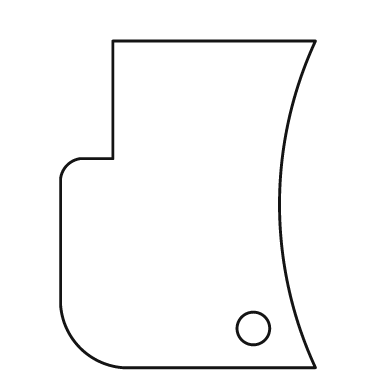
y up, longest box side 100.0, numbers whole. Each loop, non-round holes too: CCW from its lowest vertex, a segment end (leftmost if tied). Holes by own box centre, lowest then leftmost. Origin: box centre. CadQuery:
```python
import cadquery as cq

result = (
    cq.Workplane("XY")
    .moveTo(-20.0, -50.0)
    .lineTo(39.0, -50.0)
    .threePointArc((28.0, 0.0), (39.0, 50.0))
    .lineTo(-23.0, 50.0)
    .lineTo(-23.0, 14.0)
    .lineTo(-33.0, 14.0)
    .threePointArc((-37.0, 12.0), (-39.0, 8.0))
    .lineTo(-39.0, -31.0)
    .threePointArc((-33.0, -44.0), (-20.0, -50.0))
    .close()
    .moveTo(20.0, -38.0)
    .circle(5.0)
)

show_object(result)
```